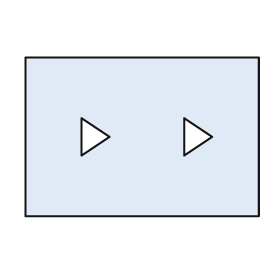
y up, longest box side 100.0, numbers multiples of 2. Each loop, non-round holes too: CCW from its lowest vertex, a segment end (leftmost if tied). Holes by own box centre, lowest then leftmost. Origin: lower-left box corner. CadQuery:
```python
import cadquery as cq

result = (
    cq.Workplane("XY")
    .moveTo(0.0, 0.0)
    .lineTo(100.0, 0.0)
    .lineTo(100.0, 68.0)
    .lineTo(0.0, 68.0)
    .close()
    .moveTo(24.0, 26.0)
    .lineTo(36.0, 34.0)
    .lineTo(24.0, 42.0)
    .close()
    .moveTo(68.0, 26.0)
    .lineTo(80.0, 34.0)
    .lineTo(68.0, 42.0)
    .close()
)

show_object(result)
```